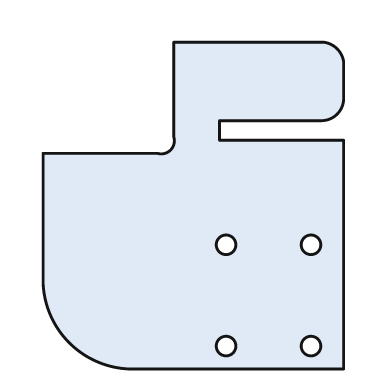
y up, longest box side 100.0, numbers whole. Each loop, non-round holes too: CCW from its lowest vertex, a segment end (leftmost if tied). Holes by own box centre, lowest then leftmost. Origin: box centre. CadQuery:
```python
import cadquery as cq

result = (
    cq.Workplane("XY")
    .moveTo(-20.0, -50.0)
    .lineTo(46.0, -50.0)
    .lineTo(46.0, 20.0)
    .lineTo(8.0, 20.0)
    .lineTo(8.0, 26.0)
    .lineTo(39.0, 26.0)
    .threePointArc((44.0, 28.0), (46.0, 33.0))
    .lineTo(46.0, 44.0)
    .threePointArc((44.0, 48.0), (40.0, 50.0))
    .lineTo(-6.0, 50.0)
    .lineTo(-6.0, 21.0)
    .threePointArc((-7.0, 17.0), (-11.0, 16.0))
    .lineTo(-46.0, 16.0)
    .lineTo(-46.0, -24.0)
    .threePointArc((-38.0, -42.0), (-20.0, -50.0))
    .close()
    .moveTo(10.0, -43.0)
    .circle(3.0)
    .moveTo(36.0, -43.0)
    .circle(3.0)
    .moveTo(10.0, -12.0)
    .circle(3.0)
    .moveTo(36.0, -12.0)
    .circle(3.0)
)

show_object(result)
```